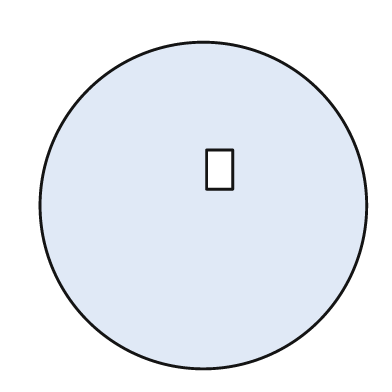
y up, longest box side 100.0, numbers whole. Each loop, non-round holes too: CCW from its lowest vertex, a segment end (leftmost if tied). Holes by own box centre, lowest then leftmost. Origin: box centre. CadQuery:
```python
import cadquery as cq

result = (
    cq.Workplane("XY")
    .moveTo(0.0, 0.0)
    .circle(50.0)
    .moveTo(1.0, 5.0)
    .lineTo(9.0, 5.0)
    .lineTo(9.0, 17.0)
    .lineTo(1.0, 17.0)
    .close()
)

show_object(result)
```